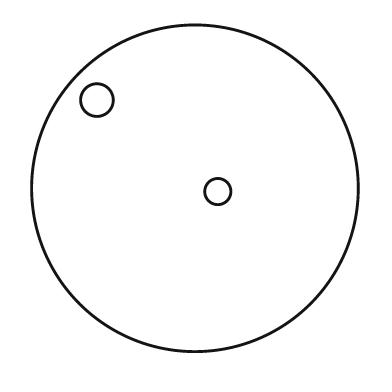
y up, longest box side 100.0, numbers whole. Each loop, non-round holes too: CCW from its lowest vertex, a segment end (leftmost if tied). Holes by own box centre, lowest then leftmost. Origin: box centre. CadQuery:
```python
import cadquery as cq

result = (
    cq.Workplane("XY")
    .moveTo(0.0, 0.0)
    .circle(50.0)
    .moveTo(7.0, -1.0)
    .circle(4.0)
    .moveTo(-30.0, 27.0)
    .circle(5.0)
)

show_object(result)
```